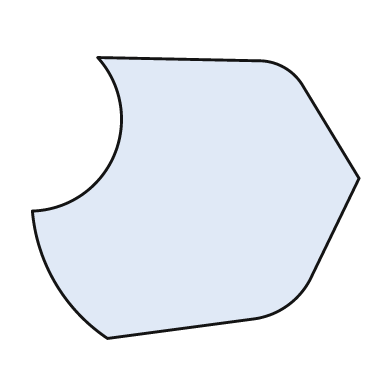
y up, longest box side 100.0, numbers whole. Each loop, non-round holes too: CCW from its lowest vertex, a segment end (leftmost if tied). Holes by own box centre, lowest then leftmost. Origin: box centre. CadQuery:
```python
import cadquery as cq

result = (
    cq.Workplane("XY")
    .moveTo(-27.0, -43.0)
    .lineTo(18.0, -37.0)
    .threePointArc((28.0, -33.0), (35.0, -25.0))
    .lineTo(50.0, 6.0)
    .lineTo(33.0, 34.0)
    .threePointArc((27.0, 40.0), (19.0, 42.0))
    .lineTo(-30.0, 43.0)
    .threePointArc((-25.0, 13.0), (-50.0, -4.0))
    .threePointArc((-43.0, -26.0), (-27.0, -43.0))
    .close()
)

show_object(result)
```